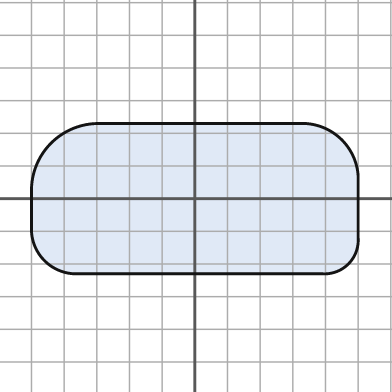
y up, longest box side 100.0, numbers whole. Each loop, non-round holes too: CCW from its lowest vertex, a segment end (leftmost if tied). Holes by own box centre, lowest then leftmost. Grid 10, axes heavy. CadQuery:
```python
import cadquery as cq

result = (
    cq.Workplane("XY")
    .moveTo(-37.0, -23.0)
    .lineTo(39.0, -23.0)
    .threePointArc((47.0, -20.0), (50.0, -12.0))
    .lineTo(50.0, 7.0)
    .threePointArc((45.0, 18.0), (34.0, 23.0))
    .lineTo(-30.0, 23.0)
    .threePointArc((-44.0, 17.0), (-50.0, 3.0))
    .lineTo(-50.0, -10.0)
    .threePointArc((-46.0, -19.0), (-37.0, -23.0))
    .close()
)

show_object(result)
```